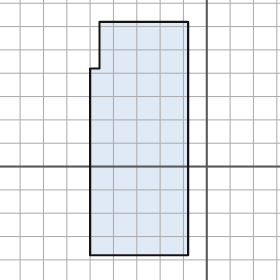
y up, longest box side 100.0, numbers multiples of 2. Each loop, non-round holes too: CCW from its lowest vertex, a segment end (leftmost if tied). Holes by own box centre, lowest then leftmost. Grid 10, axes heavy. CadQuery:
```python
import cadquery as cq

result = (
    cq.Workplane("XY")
    .moveTo(-50.0, -38.0)
    .lineTo(-8.0, -38.0)
    .lineTo(-8.0, 62.0)
    .lineTo(-46.0, 62.0)
    .lineTo(-46.0, 42.0)
    .lineTo(-50.0, 42.0)
    .close()
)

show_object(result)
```